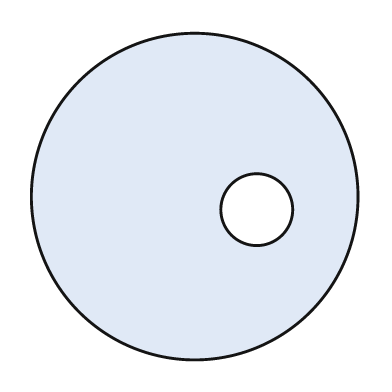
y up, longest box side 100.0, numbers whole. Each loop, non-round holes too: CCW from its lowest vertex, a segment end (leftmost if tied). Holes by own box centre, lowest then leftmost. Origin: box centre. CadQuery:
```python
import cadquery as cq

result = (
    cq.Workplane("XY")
    .moveTo(0.0, 0.0)
    .circle(50.0)
    .moveTo(19.0, -4.0)
    .circle(11.0)
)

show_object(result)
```